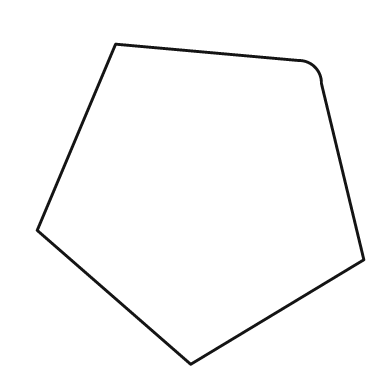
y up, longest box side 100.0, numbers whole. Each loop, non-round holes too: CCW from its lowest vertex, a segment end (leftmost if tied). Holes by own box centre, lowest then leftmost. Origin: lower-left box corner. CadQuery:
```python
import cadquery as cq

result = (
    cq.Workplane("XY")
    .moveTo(47.0, 0.0)
    .lineTo(100.0, 32.0)
    .lineTo(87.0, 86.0)
    .threePointArc((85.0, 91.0), (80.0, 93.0))
    .lineTo(24.0, 98.0)
    .lineTo(0.0, 41.0)
    .close()
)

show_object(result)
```